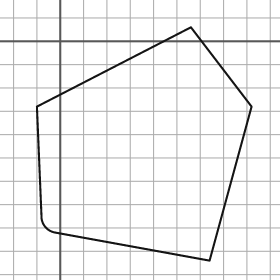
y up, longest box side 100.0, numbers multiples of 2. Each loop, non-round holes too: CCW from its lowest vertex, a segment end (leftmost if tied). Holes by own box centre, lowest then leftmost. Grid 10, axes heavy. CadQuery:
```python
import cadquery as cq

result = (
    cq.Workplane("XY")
    .moveTo(64.0, -94.0)
    .lineTo(82.0, -28.0)
    .lineTo(56.0, 6.0)
    .lineTo(-10.0, -28.0)
    .lineTo(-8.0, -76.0)
    .threePointArc((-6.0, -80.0), (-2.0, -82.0))
    .close()
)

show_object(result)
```